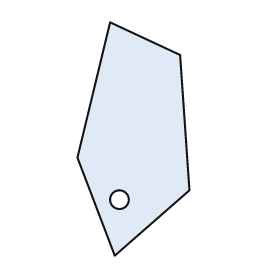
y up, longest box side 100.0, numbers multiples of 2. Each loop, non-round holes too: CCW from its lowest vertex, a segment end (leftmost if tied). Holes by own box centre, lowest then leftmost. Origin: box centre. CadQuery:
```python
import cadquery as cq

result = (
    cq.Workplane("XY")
    .moveTo(-8.0, -50.0)
    .lineTo(24.0, -22.0)
    .lineTo(20.0, 36.0)
    .lineTo(-10.0, 50.0)
    .lineTo(-24.0, -8.0)
    .close()
    .moveTo(-6.0, -26.0)
    .circle(4.0)
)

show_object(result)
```